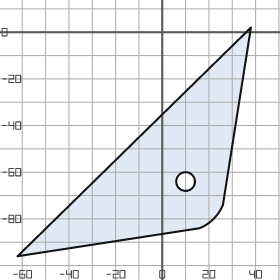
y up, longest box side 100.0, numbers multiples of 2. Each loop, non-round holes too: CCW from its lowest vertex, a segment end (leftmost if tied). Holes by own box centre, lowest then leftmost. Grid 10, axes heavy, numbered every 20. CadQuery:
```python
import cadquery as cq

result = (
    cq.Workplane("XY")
    .moveTo(-62.0, -96.0)
    .lineTo(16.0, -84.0)
    .threePointArc((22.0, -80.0), (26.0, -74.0))
    .lineTo(38.0, 2.0)
    .close()
    .moveTo(10.0, -64.0)
    .circle(4.0)
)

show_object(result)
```